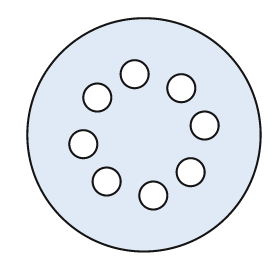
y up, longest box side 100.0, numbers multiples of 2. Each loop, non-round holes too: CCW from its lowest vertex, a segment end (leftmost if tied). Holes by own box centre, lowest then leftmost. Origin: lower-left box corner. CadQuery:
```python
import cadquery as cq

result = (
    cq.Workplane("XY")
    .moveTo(50.0, 50.0)
    .circle(50.0)
    .moveTo(54.0, 24.0)
    .circle(6.0)
    .moveTo(34.0, 30.0)
    .circle(6.0)
    .moveTo(70.0, 34.0)
    .circle(6.0)
    .moveTo(24.0, 46.0)
    .circle(6.0)
    .moveTo(76.0, 54.0)
    .circle(6.0)
    .moveTo(30.0, 66.0)
    .circle(6.0)
    .moveTo(66.0, 70.0)
    .circle(6.0)
    .moveTo(46.0, 76.0)
    .circle(6.0)
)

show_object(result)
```